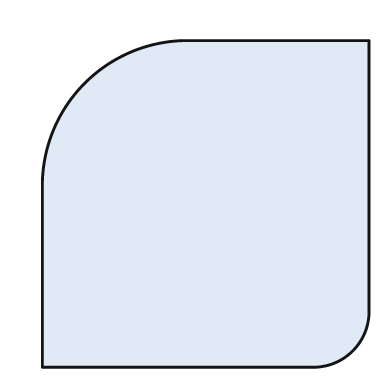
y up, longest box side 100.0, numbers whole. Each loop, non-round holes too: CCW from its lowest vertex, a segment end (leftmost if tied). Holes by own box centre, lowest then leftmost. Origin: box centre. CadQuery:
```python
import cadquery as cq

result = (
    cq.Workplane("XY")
    .moveTo(-50.0, -50.0)
    .lineTo(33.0, -50.0)
    .threePointArc((45.0, -45.0), (50.0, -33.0))
    .lineTo(50.0, 50.0)
    .lineTo(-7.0, 50.0)
    .threePointArc((-37.0, 37.0), (-50.0, 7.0))
    .close()
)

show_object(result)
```